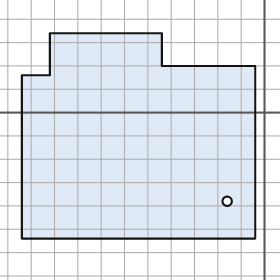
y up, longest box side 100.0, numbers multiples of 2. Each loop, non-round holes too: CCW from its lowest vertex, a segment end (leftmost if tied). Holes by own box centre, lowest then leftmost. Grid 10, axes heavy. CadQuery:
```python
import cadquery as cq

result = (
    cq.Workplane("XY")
    .moveTo(-104.0, -54.0)
    .lineTo(-4.0, -54.0)
    .lineTo(-4.0, 20.0)
    .lineTo(-44.0, 20.0)
    .lineTo(-44.0, 34.0)
    .lineTo(-92.0, 34.0)
    .lineTo(-92.0, 16.0)
    .lineTo(-104.0, 16.0)
    .close()
    .moveTo(-16.0, -38.0)
    .circle(2.0)
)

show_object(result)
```